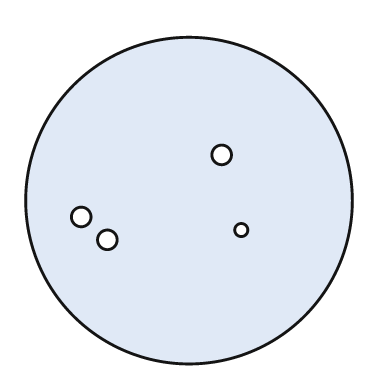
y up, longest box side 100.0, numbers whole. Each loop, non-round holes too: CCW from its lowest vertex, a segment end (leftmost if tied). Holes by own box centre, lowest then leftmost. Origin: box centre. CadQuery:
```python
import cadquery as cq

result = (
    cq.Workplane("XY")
    .moveTo(0.0, 0.0)
    .circle(50.0)
    .moveTo(-25.0, -12.0)
    .circle(3.0)
    .moveTo(16.0, -9.0)
    .circle(2.0)
    .moveTo(-33.0, -5.0)
    .circle(3.0)
    .moveTo(10.0, 14.0)
    .circle(3.0)
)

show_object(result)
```